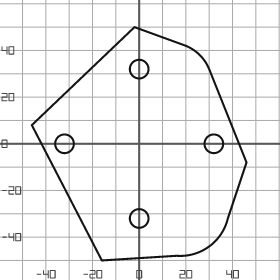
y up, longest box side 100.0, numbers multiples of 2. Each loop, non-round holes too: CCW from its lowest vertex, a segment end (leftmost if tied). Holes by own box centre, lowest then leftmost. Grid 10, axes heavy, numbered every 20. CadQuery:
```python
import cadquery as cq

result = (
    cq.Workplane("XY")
    .moveTo(-16.0, -50.0)
    .lineTo(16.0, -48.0)
    .threePointArc((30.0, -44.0), (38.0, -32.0))
    .lineTo(46.0, -8.0)
    .lineTo(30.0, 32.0)
    .threePointArc((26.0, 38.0), (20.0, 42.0))
    .lineTo(-2.0, 50.0)
    .lineTo(-46.0, 8.0)
    .close()
    .moveTo(0.0, -32.0)
    .circle(4.0)
    .moveTo(-32.0, 0.0)
    .circle(4.0)
    .moveTo(32.0, 0.0)
    .circle(4.0)
    .moveTo(0.0, 32.0)
    .circle(4.0)
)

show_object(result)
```